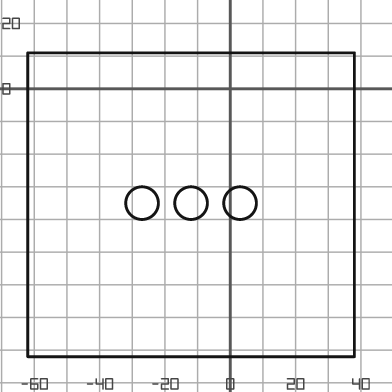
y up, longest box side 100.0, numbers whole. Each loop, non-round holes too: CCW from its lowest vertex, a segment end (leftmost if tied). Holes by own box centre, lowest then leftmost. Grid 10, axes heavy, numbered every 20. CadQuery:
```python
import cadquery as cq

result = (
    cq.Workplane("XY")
    .moveTo(-62.0, -82.0)
    .lineTo(38.0, -82.0)
    .lineTo(38.0, 11.0)
    .lineTo(-62.0, 11.0)
    .close()
    .moveTo(-27.0, -35.0)
    .circle(5.0)
    .moveTo(-12.0, -35.0)
    .circle(5.0)
    .moveTo(3.0, -35.0)
    .circle(5.0)
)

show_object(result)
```